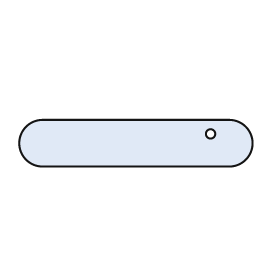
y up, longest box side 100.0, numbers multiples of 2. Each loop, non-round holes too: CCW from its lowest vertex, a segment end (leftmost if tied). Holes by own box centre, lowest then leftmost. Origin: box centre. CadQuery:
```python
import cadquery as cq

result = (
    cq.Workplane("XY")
    .moveTo(-40.0, -10.0)
    .lineTo(40.0, -10.0)
    .threePointArc((50.0, 0.0), (40.0, 10.0))
    .lineTo(-40.0, 10.0)
    .threePointArc((-50.0, 0.0), (-40.0, -10.0))
    .close()
    .moveTo(32.0, 4.0)
    .circle(2.0)
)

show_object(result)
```